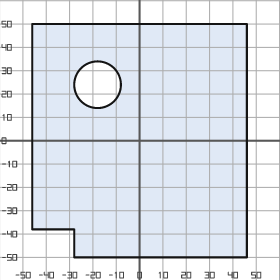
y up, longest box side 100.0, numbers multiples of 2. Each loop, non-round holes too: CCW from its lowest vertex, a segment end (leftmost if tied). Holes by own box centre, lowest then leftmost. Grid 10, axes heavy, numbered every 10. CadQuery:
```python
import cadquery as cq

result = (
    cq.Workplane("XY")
    .moveTo(-28.0, -50.0)
    .lineTo(46.0, -50.0)
    .lineTo(46.0, 50.0)
    .lineTo(-46.0, 50.0)
    .lineTo(-46.0, -38.0)
    .lineTo(-28.0, -38.0)
    .close()
    .moveTo(-18.0, 24.0)
    .circle(10.0)
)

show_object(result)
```